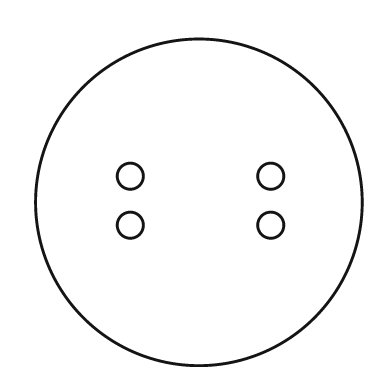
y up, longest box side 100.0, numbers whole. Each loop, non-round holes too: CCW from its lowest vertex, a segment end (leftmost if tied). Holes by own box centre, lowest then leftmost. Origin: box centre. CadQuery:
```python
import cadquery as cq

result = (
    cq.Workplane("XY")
    .moveTo(0.0, 0.0)
    .circle(50.0)
    .moveTo(-21.0, -7.0)
    .circle(4.0)
    .moveTo(22.0, -7.0)
    .circle(4.0)
    .moveTo(-21.0, 8.0)
    .circle(4.0)
    .moveTo(22.0, 8.0)
    .circle(4.0)
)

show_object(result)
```